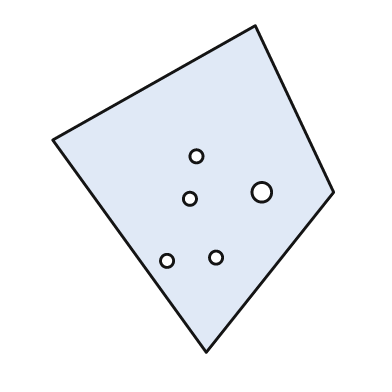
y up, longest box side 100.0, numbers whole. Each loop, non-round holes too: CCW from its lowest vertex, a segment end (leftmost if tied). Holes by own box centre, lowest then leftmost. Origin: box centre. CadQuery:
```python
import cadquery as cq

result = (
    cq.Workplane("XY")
    .moveTo(4.0, -50.0)
    .lineTo(43.0, -1.0)
    .lineTo(19.0, 50.0)
    .lineTo(-43.0, 15.0)
    .close()
    .moveTo(-8.0, -22.0)
    .circle(2.0)
    .moveTo(7.0, -21.0)
    .circle(2.0)
    .moveTo(-1.0, -3.0)
    .circle(2.0)
    .moveTo(21.0, -1.0)
    .circle(3.0)
    .moveTo(1.0, 10.0)
    .circle(2.0)
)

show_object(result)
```